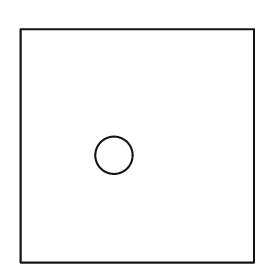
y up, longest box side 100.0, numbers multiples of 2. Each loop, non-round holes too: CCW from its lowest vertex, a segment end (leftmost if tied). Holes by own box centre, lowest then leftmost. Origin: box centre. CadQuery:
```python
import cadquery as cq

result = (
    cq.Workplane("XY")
    .moveTo(-50.0, -50.0)
    .lineTo(50.0, -50.0)
    .lineTo(50.0, 50.0)
    .lineTo(-50.0, 50.0)
    .close()
    .moveTo(-10.0, -4.0)
    .circle(8.0)
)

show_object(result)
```